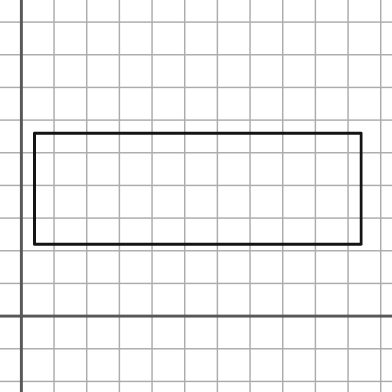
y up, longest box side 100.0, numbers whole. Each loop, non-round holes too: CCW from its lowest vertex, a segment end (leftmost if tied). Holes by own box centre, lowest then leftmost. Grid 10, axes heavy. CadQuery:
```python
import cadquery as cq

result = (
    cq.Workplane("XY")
    .moveTo(4.0, 22.0)
    .lineTo(104.0, 22.0)
    .lineTo(104.0, 56.0)
    .lineTo(4.0, 56.0)
    .close()
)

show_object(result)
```